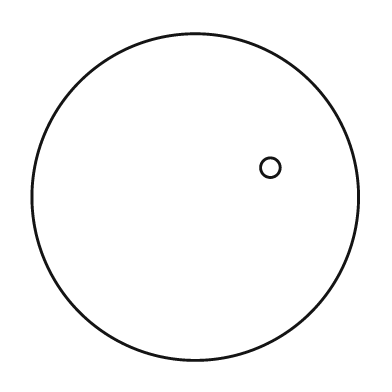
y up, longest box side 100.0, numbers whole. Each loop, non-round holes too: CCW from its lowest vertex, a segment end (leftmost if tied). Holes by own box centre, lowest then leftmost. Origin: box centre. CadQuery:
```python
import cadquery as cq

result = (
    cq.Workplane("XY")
    .moveTo(0.0, 0.0)
    .circle(50.0)
    .moveTo(23.0, 9.0)
    .circle(3.0)
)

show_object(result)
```